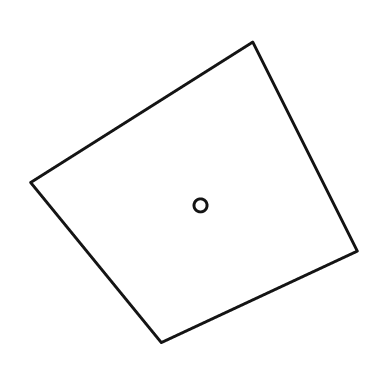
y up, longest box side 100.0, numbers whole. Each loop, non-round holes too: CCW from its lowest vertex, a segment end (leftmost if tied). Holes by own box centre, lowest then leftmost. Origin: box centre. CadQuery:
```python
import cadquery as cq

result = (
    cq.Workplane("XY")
    .moveTo(-10.0, -46.0)
    .lineTo(50.0, -18.0)
    .lineTo(18.0, 46.0)
    .lineTo(-50.0, 3.0)
    .close()
    .moveTo(2.0, -4.0)
    .circle(2.0)
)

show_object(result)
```